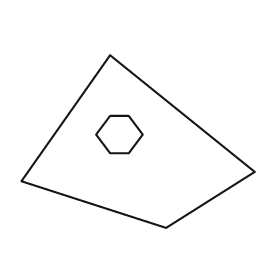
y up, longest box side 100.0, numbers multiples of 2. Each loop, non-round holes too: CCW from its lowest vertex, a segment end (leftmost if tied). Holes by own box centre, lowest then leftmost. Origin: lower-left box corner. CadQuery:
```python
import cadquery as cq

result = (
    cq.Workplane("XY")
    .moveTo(62.0, 0.0)
    .lineTo(100.0, 24.0)
    .lineTo(38.0, 74.0)
    .lineTo(0.0, 20.0)
    .close()
    .moveTo(38.0, 32.0)
    .lineTo(46.0, 32.0)
    .lineTo(52.0, 40.0)
    .lineTo(46.0, 48.0)
    .lineTo(38.0, 48.0)
    .lineTo(32.0, 40.0)
    .close()
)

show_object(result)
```